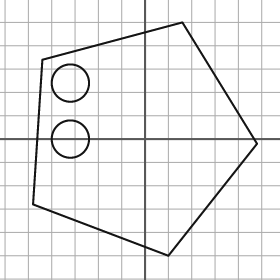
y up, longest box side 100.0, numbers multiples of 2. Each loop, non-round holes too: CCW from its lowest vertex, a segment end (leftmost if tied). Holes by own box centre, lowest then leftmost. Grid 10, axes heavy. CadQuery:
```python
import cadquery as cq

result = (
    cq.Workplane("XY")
    .moveTo(10.0, -50.0)
    .lineTo(48.0, -2.0)
    .lineTo(16.0, 50.0)
    .lineTo(-44.0, 34.0)
    .lineTo(-48.0, -28.0)
    .close()
    .moveTo(-32.0, 0.0)
    .circle(8.0)
    .moveTo(-32.0, 24.0)
    .circle(8.0)
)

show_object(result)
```